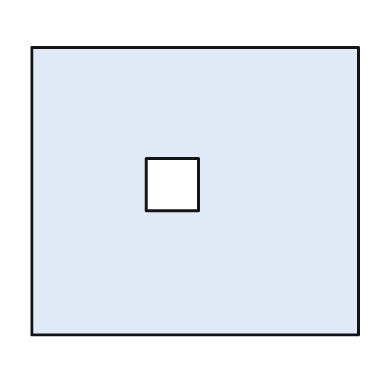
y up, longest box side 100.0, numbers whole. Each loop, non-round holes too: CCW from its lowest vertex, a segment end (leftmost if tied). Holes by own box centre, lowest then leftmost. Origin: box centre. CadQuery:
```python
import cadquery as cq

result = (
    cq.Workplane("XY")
    .moveTo(-50.0, -44.0)
    .lineTo(50.0, -44.0)
    .lineTo(50.0, 44.0)
    .lineTo(-50.0, 44.0)
    .close()
    .moveTo(-15.0, -6.0)
    .lineTo(1.0, -6.0)
    .lineTo(1.0, 10.0)
    .lineTo(-15.0, 10.0)
    .close()
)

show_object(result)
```